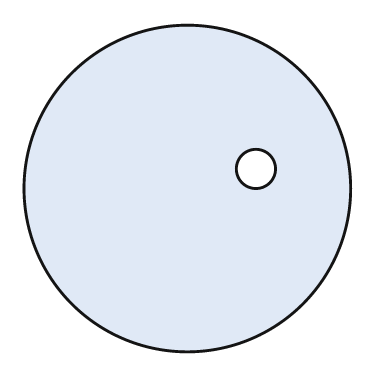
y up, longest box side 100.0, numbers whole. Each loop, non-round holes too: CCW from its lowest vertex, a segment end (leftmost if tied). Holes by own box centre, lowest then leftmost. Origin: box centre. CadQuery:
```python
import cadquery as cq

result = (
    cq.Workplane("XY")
    .moveTo(0.0, 0.0)
    .circle(50.0)
    .moveTo(21.0, 6.0)
    .circle(6.0)
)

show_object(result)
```